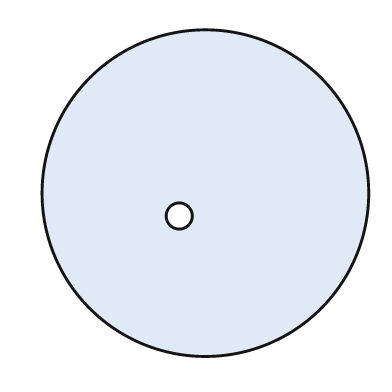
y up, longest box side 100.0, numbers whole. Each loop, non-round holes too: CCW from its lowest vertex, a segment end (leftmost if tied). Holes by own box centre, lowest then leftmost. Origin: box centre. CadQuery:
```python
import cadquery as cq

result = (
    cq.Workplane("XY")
    .moveTo(0.0, 0.0)
    .circle(50.0)
    .moveTo(-8.0, -7.0)
    .circle(4.0)
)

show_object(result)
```